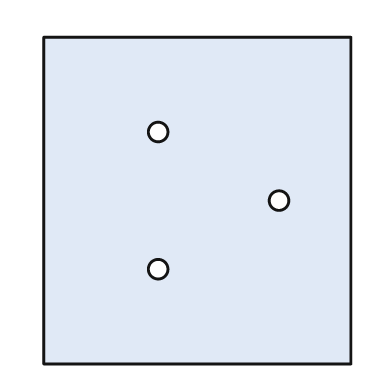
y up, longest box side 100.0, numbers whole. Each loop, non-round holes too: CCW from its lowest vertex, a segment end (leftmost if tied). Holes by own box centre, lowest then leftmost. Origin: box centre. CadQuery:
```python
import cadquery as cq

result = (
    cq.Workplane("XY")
    .moveTo(-47.0, -50.0)
    .lineTo(47.0, -50.0)
    .lineTo(47.0, 50.0)
    .lineTo(-47.0, 50.0)
    .close()
    .moveTo(-12.0, -21.0)
    .circle(3.0)
    .moveTo(25.0, 0.0)
    .circle(3.0)
    .moveTo(-12.0, 21.0)
    .circle(3.0)
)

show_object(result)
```